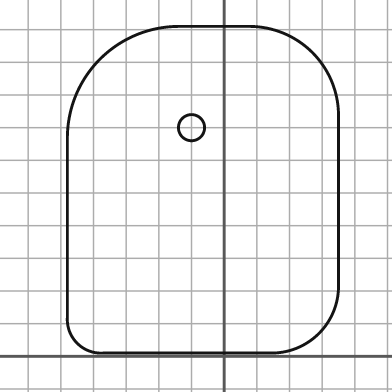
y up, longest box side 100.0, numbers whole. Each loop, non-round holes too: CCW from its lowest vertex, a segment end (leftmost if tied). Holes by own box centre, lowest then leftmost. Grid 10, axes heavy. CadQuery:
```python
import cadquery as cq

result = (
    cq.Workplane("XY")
    .moveTo(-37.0, 1.0)
    .lineTo(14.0, 1.0)
    .threePointArc((29.0, 7.0), (35.0, 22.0))
    .lineTo(35.0, 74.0)
    .threePointArc((27.0, 93.0), (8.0, 101.0))
    .lineTo(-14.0, 101.0)
    .threePointArc((-38.0, 91.0), (-48.0, 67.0))
    .lineTo(-48.0, 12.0)
    .threePointArc((-45.0, 4.0), (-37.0, 1.0))
    .close()
    .moveTo(-10.0, 70.0)
    .circle(4.0)
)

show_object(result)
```